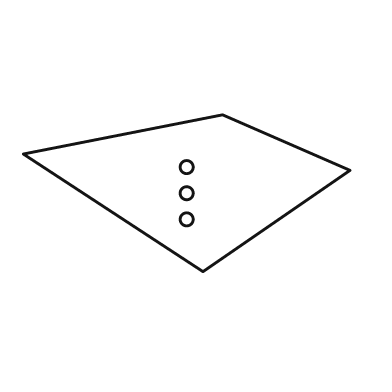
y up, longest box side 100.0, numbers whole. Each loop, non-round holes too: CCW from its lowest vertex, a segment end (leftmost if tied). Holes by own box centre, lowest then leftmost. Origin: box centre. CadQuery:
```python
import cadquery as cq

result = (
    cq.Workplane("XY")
    .moveTo(5.0, -24.0)
    .lineTo(50.0, 7.0)
    .lineTo(11.0, 24.0)
    .lineTo(-50.0, 12.0)
    .close()
    .moveTo(0.0, -8.0)
    .circle(2.0)
    .moveTo(0.0, 0.0)
    .circle(2.0)
    .moveTo(0.0, 8.0)
    .circle(2.0)
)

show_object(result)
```